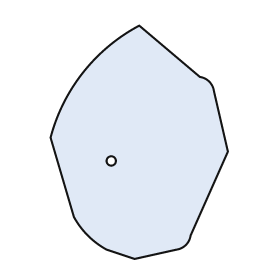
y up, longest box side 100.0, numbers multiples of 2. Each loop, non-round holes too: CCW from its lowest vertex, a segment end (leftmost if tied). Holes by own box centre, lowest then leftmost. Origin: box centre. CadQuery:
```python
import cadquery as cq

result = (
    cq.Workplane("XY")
    .moveTo(-2.0, -50.0)
    .lineTo(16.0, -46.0)
    .threePointArc((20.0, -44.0), (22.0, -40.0))
    .lineTo(38.0, -4.0)
    .lineTo(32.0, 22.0)
    .threePointArc((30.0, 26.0), (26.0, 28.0))
    .lineTo(0.0, 50.0)
    .threePointArc((-24.0, 30.0), (-38.0, 2.0))
    .lineTo(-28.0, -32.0)
    .threePointArc((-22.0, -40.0), (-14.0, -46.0))
    .close()
    .moveTo(-12.0, -8.0)
    .circle(2.0)
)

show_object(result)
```